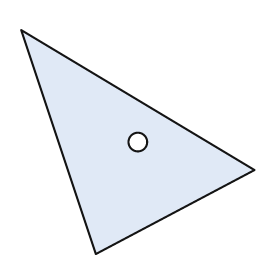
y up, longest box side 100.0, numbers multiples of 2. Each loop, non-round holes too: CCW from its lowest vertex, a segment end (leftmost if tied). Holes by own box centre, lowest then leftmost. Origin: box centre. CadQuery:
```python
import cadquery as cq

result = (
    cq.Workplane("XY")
    .moveTo(-18.0, -48.0)
    .lineTo(50.0, -12.0)
    .lineTo(-50.0, 48.0)
    .close()
    .moveTo(0.0, 0.0)
    .circle(4.0)
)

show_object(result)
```